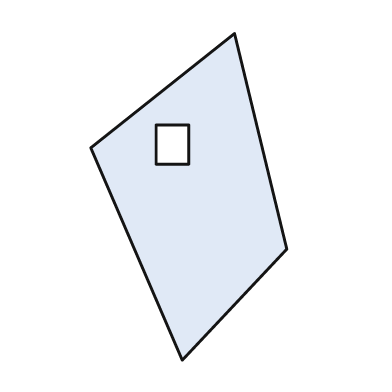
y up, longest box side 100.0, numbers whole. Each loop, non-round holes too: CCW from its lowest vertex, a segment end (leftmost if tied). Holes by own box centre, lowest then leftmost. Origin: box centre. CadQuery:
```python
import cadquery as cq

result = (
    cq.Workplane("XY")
    .moveTo(-2.0, -50.0)
    .lineTo(30.0, -16.0)
    .lineTo(14.0, 50.0)
    .lineTo(-30.0, 15.0)
    .close()
    .moveTo(-10.0, 10.0)
    .lineTo(0.0, 10.0)
    .lineTo(0.0, 22.0)
    .lineTo(-10.0, 22.0)
    .close()
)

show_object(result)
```